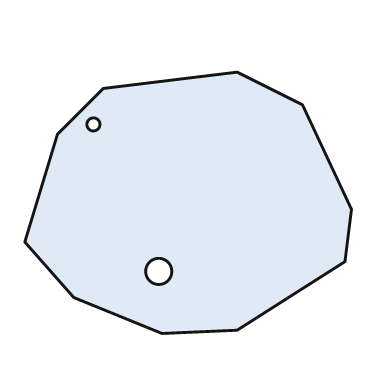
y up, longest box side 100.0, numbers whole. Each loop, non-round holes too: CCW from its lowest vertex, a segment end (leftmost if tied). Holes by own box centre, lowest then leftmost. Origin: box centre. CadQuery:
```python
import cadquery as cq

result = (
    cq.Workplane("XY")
    .moveTo(-8.0, -40.0)
    .lineTo(15.0, -39.0)
    .lineTo(48.0, -18.0)
    .lineTo(50.0, -2.0)
    .lineTo(35.0, 30.0)
    .lineTo(15.0, 40.0)
    .lineTo(-26.0, 35.0)
    .lineTo(-40.0, 21.0)
    .lineTo(-50.0, -12.0)
    .lineTo(-35.0, -29.0)
    .close()
    .moveTo(-9.0, -21.0)
    .circle(4.0)
    .moveTo(-29.0, 24.0)
    .circle(2.0)
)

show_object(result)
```